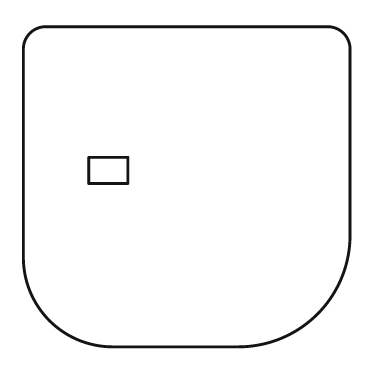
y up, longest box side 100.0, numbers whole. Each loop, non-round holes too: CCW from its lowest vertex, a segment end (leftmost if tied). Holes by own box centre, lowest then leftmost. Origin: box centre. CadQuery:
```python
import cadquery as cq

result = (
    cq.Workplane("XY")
    .moveTo(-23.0, -49.0)
    .lineTo(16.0, -49.0)
    .threePointArc((40.0, -39.0), (50.0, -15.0))
    .lineTo(50.0, 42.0)
    .threePointArc((48.0, 47.0), (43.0, 49.0))
    .lineTo(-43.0, 49.0)
    .threePointArc((-48.0, 47.0), (-50.0, 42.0))
    .lineTo(-50.0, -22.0)
    .threePointArc((-42.0, -41.0), (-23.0, -49.0))
    .close()
    .moveTo(-30.0, 1.0)
    .lineTo(-18.0, 1.0)
    .lineTo(-18.0, 9.0)
    .lineTo(-30.0, 9.0)
    .close()
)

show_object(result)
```